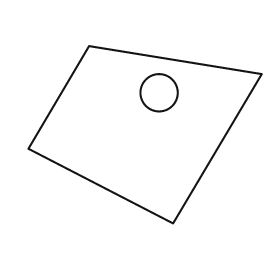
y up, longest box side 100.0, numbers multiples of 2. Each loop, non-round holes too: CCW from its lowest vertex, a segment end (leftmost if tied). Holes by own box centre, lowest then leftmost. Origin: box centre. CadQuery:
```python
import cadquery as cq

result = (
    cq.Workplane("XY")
    .moveTo(12.0, -38.0)
    .lineTo(50.0, 26.0)
    .lineTo(-24.0, 38.0)
    .lineTo(-50.0, -6.0)
    .close()
    .moveTo(6.0, 18.0)
    .circle(8.0)
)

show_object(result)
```